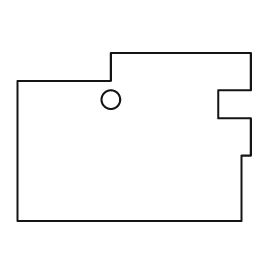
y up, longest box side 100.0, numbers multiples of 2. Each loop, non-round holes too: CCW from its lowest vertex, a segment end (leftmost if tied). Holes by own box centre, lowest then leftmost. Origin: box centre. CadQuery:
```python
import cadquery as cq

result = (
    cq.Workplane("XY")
    .moveTo(-50.0, -36.0)
    .lineTo(46.0, -36.0)
    .lineTo(46.0, -8.0)
    .lineTo(50.0, -8.0)
    .lineTo(50.0, 8.0)
    .lineTo(36.0, 8.0)
    .lineTo(36.0, 20.0)
    .lineTo(50.0, 20.0)
    .lineTo(50.0, 36.0)
    .lineTo(-10.0, 36.0)
    .lineTo(-10.0, 24.0)
    .lineTo(-50.0, 24.0)
    .close()
    .moveTo(-10.0, 16.0)
    .circle(4.0)
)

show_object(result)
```